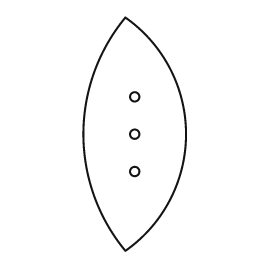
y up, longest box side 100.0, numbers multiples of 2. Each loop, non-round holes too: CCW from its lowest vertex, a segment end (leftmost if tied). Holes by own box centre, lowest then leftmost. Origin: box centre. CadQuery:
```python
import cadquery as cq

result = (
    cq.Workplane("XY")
    .moveTo(-4.0, -50.0)
    .threePointArc((22.0, 0.0), (-4.0, 50.0))
    .threePointArc((-22.0, 0.0), (-4.0, -50.0))
    .close()
    .moveTo(0.0, -16.0)
    .circle(2.0)
    .moveTo(0.0, 0.0)
    .circle(2.0)
    .moveTo(0.0, 16.0)
    .circle(2.0)
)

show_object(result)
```